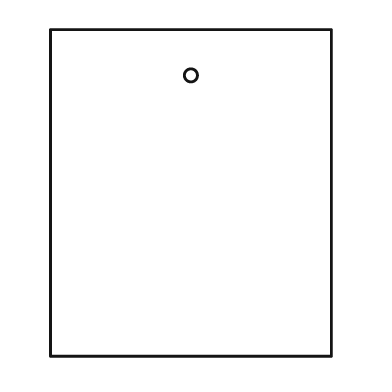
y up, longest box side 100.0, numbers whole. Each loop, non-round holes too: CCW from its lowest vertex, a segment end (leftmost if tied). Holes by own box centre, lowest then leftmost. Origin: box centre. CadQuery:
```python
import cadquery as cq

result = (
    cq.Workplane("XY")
    .moveTo(-43.0, -50.0)
    .lineTo(43.0, -50.0)
    .lineTo(43.0, 50.0)
    .lineTo(-43.0, 50.0)
    .close()
    .moveTo(0.0, 36.0)
    .circle(2.0)
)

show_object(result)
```